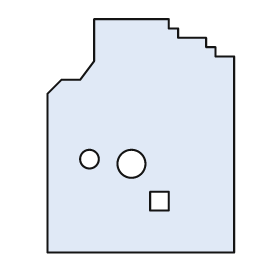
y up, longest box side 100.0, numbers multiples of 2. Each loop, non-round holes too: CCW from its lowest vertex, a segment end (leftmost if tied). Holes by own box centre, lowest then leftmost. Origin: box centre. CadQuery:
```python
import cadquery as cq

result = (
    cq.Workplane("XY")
    .moveTo(-40.0, -50.0)
    .lineTo(40.0, -50.0)
    .lineTo(40.0, 34.0)
    .lineTo(32.0, 34.0)
    .lineTo(32.0, 38.0)
    .lineTo(28.0, 38.0)
    .lineTo(28.0, 42.0)
    .lineTo(16.0, 42.0)
    .lineTo(16.0, 46.0)
    .lineTo(12.0, 46.0)
    .lineTo(12.0, 50.0)
    .lineTo(-20.0, 50.0)
    .lineTo(-20.0, 32.0)
    .lineTo(-26.0, 24.0)
    .lineTo(-34.0, 24.0)
    .lineTo(-40.0, 18.0)
    .close()
    .moveTo(4.0, -32.0)
    .lineTo(12.0, -32.0)
    .lineTo(12.0, -24.0)
    .lineTo(4.0, -24.0)
    .close()
    .moveTo(-4.0, -12.0)
    .circle(6.0)
    .moveTo(-22.0, -10.0)
    .circle(4.0)
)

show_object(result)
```